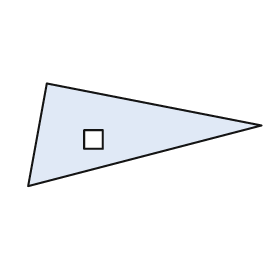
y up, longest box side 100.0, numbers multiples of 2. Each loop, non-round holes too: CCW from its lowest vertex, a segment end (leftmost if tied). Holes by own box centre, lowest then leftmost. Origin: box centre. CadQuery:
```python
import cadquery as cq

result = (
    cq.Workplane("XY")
    .moveTo(-50.0, -22.0)
    .lineTo(50.0, 4.0)
    .lineTo(-42.0, 22.0)
    .close()
    .moveTo(-26.0, -6.0)
    .lineTo(-18.0, -6.0)
    .lineTo(-18.0, 2.0)
    .lineTo(-26.0, 2.0)
    .close()
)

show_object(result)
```